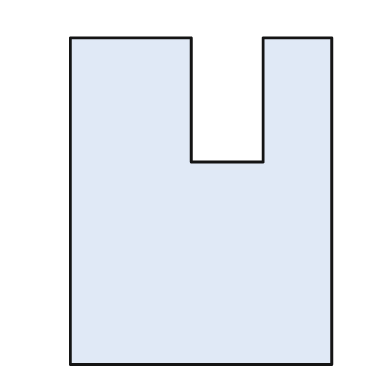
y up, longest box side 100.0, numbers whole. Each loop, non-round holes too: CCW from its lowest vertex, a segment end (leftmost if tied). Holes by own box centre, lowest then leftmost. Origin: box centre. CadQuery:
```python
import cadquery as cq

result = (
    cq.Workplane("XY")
    .moveTo(-40.0, -50.0)
    .lineTo(40.0, -50.0)
    .lineTo(40.0, 50.0)
    .lineTo(19.0, 50.0)
    .lineTo(19.0, 12.0)
    .lineTo(-3.0, 12.0)
    .lineTo(-3.0, 50.0)
    .lineTo(-40.0, 50.0)
    .close()
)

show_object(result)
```